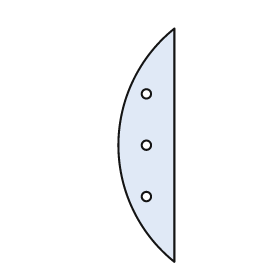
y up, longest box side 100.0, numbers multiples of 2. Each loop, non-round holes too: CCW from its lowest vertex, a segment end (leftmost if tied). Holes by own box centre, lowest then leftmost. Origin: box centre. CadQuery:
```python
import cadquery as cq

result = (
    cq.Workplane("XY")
    .moveTo(12.0, -50.0)
    .lineTo(12.0, 50.0)
    .threePointArc((-12.0, 0.0), (12.0, -50.0))
    .close()
    .moveTo(0.0, -22.0)
    .circle(2.0)
    .moveTo(0.0, 0.0)
    .circle(2.0)
    .moveTo(0.0, 22.0)
    .circle(2.0)
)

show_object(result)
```